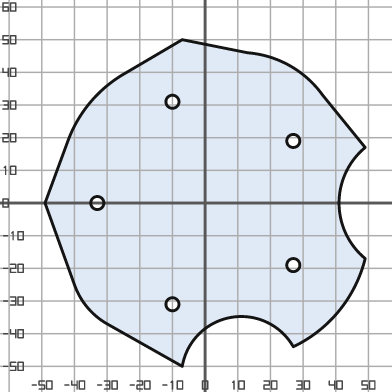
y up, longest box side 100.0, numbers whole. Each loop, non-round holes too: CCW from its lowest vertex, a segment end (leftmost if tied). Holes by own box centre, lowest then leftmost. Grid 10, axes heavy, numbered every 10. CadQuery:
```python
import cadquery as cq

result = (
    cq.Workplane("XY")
    .moveTo(-7.0, -50.0)
    .threePointArc((8.0, -35.0), (27.0, -44.0))
    .threePointArc((41.0, -33.0), (49.0, -17.0))
    .threePointArc((41.0, 0.0), (49.0, 17.0))
    .lineTo(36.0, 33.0)
    .threePointArc((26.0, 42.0), (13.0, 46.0))
    .lineTo(-7.0, 50.0)
    .lineTo(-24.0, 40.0)
    .threePointArc((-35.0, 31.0), (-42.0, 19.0))
    .lineTo(-49.0, 0.0)
    .lineTo(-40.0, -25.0)
    .threePointArc((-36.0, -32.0), (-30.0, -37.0))
    .close()
    .moveTo(-10.0, -31.0)
    .circle(2.0)
    .moveTo(27.0, -19.0)
    .circle(2.0)
    .moveTo(-33.0, 0.0)
    .circle(2.0)
    .moveTo(27.0, 19.0)
    .circle(2.0)
    .moveTo(-10.0, 31.0)
    .circle(2.0)
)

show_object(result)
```